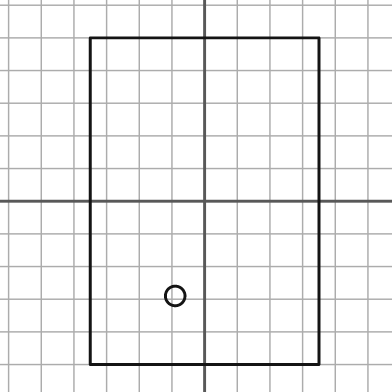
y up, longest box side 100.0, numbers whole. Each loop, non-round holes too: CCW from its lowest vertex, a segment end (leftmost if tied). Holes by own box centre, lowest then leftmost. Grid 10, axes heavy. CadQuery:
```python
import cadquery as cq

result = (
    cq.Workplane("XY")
    .moveTo(-35.0, -50.0)
    .lineTo(35.0, -50.0)
    .lineTo(35.0, 50.0)
    .lineTo(-35.0, 50.0)
    .close()
    .moveTo(-9.0, -29.0)
    .circle(3.0)
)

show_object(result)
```